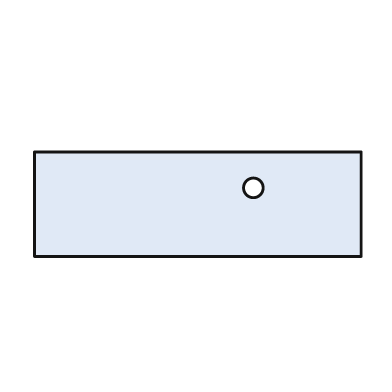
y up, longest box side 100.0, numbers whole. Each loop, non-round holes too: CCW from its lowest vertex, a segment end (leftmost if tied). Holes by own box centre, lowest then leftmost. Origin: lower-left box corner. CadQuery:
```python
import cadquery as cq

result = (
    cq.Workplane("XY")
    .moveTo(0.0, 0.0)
    .lineTo(100.0, 0.0)
    .lineTo(100.0, 32.0)
    .lineTo(0.0, 32.0)
    .close()
    .moveTo(67.0, 21.0)
    .circle(3.0)
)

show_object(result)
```